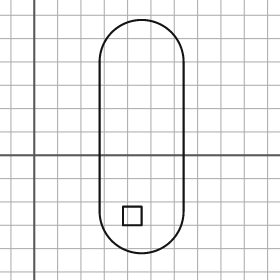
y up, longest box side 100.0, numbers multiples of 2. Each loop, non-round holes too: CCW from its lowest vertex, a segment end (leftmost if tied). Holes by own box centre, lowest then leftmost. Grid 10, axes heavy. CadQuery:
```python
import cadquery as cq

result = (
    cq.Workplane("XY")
    .moveTo(28.0, -24.0)
    .threePointArc((46.0, -42.0), (64.0, -24.0))
    .lineTo(64.0, 40.0)
    .threePointArc((46.0, 58.0), (28.0, 40.0))
    .close()
    .moveTo(38.0, -30.0)
    .lineTo(46.0, -30.0)
    .lineTo(46.0, -22.0)
    .lineTo(38.0, -22.0)
    .close()
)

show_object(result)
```